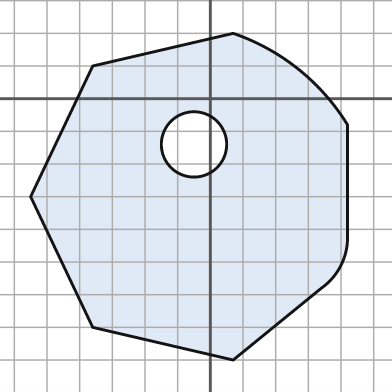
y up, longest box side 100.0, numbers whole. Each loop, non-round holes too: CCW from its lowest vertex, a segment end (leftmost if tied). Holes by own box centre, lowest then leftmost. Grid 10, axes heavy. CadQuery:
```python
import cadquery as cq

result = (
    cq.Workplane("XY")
    .moveTo(7.0, -80.0)
    .lineTo(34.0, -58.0)
    .threePointArc((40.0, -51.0), (42.0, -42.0))
    .lineTo(42.0, -8.0)
    .threePointArc((27.0, 9.0), (7.0, 20.0))
    .lineTo(-36.0, 10.0)
    .lineTo(-55.0, -30.0)
    .lineTo(-36.0, -70.0)
    .close()
    .moveTo(-5.0, -14.0)
    .circle(10.0)
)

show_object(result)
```